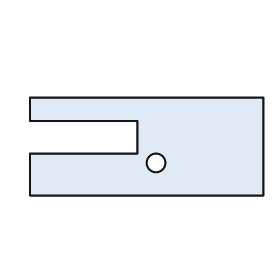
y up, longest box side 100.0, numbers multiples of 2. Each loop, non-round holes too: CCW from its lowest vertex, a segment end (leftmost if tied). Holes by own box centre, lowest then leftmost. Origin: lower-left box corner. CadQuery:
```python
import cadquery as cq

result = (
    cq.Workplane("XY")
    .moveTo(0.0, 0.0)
    .lineTo(100.0, 0.0)
    .lineTo(100.0, 42.0)
    .lineTo(0.0, 42.0)
    .lineTo(0.0, 32.0)
    .lineTo(46.0, 32.0)
    .lineTo(46.0, 18.0)
    .lineTo(0.0, 18.0)
    .close()
    .moveTo(54.0, 14.0)
    .circle(4.0)
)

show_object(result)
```